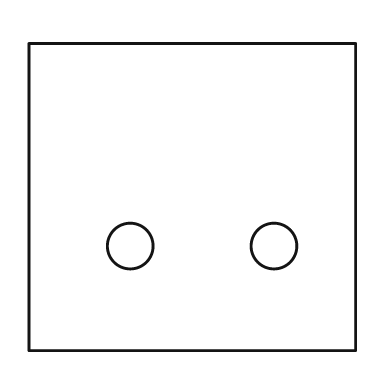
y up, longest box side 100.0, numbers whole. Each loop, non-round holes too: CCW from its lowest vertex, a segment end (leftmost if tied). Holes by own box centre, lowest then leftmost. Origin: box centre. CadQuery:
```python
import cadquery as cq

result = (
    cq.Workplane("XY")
    .moveTo(-50.0, -47.0)
    .lineTo(50.0, -47.0)
    .lineTo(50.0, 47.0)
    .lineTo(-50.0, 47.0)
    .close()
    .moveTo(-19.0, -15.0)
    .circle(7.0)
    .moveTo(25.0, -15.0)
    .circle(7.0)
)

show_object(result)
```